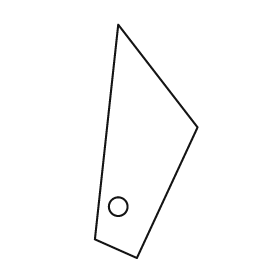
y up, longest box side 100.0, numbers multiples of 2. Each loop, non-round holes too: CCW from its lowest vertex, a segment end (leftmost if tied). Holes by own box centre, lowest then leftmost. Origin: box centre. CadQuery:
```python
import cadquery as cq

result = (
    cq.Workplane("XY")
    .moveTo(-4.0, -50.0)
    .lineTo(22.0, 6.0)
    .lineTo(-12.0, 50.0)
    .lineTo(-22.0, -42.0)
    .close()
    .moveTo(-12.0, -28.0)
    .circle(4.0)
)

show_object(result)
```